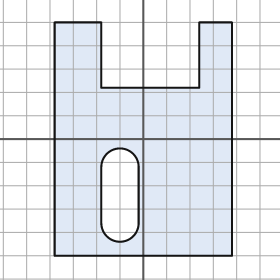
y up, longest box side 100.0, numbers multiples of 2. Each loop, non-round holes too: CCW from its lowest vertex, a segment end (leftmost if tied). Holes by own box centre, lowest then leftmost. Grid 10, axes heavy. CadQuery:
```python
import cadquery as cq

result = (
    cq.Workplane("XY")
    .moveTo(-38.0, -50.0)
    .lineTo(38.0, -50.0)
    .lineTo(38.0, 50.0)
    .lineTo(24.0, 50.0)
    .lineTo(24.0, 22.0)
    .lineTo(-18.0, 22.0)
    .lineTo(-18.0, 50.0)
    .lineTo(-38.0, 50.0)
    .close()
    .moveTo(-18.0, -36.0)
    .threePointArc((-10.0, -44.0), (-2.0, -36.0))
    .lineTo(-2.0, -12.0)
    .threePointArc((-10.0, -4.0), (-18.0, -12.0))
    .close()
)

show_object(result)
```